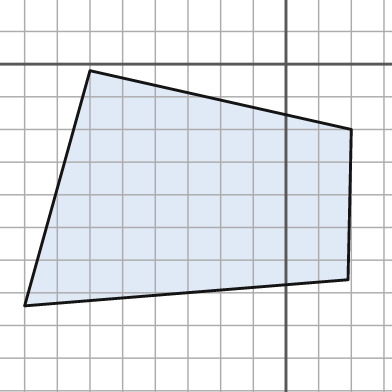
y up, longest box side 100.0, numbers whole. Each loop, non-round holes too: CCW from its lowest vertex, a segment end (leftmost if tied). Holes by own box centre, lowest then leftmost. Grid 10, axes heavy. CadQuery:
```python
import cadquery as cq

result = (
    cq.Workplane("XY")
    .moveTo(-80.0, -74.0)
    .lineTo(19.0, -66.0)
    .lineTo(20.0, -20.0)
    .lineTo(-60.0, -2.0)
    .close()
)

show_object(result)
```